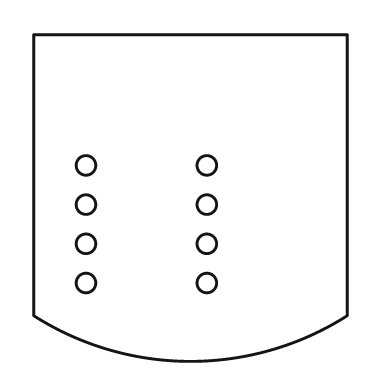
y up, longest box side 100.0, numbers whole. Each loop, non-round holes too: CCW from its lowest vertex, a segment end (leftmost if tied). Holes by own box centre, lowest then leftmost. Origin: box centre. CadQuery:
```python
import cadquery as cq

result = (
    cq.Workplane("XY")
    .moveTo(-48.0, -36.0)
    .threePointArc((0.0, -50.0), (48.0, -36.0))
    .lineTo(48.0, 50.0)
    .lineTo(-48.0, 50.0)
    .close()
    .moveTo(-32.0, -26.0)
    .circle(3.0)
    .moveTo(5.0, -26.0)
    .circle(3.0)
    .moveTo(-32.0, -14.0)
    .circle(3.0)
    .moveTo(5.0, -14.0)
    .circle(3.0)
    .moveTo(-32.0, -2.0)
    .circle(3.0)
    .moveTo(5.0, -2.0)
    .circle(3.0)
    .moveTo(-32.0, 10.0)
    .circle(3.0)
    .moveTo(5.0, 10.0)
    .circle(3.0)
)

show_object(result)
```